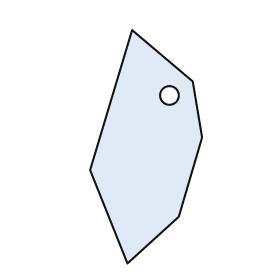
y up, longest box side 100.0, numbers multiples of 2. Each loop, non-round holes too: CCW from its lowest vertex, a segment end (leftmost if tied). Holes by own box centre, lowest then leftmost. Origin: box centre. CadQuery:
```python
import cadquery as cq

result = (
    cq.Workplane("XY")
    .moveTo(-8.0, -50.0)
    .lineTo(14.0, -30.0)
    .lineTo(24.0, 4.0)
    .lineTo(20.0, 28.0)
    .lineTo(-6.0, 50.0)
    .lineTo(-24.0, -10.0)
    .close()
    .moveTo(10.0, 22.0)
    .circle(4.0)
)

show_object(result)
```